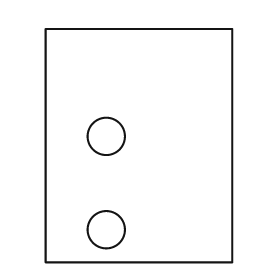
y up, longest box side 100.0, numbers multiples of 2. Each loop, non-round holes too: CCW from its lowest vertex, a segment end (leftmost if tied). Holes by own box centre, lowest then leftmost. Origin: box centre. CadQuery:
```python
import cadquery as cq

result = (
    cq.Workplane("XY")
    .moveTo(-40.0, -50.0)
    .lineTo(40.0, -50.0)
    .lineTo(40.0, 50.0)
    .lineTo(-40.0, 50.0)
    .close()
    .moveTo(-14.0, -36.0)
    .circle(8.0)
    .moveTo(-14.0, 4.0)
    .circle(8.0)
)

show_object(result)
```